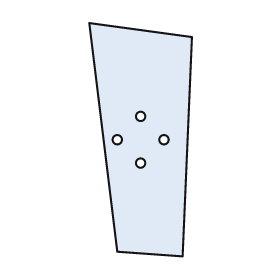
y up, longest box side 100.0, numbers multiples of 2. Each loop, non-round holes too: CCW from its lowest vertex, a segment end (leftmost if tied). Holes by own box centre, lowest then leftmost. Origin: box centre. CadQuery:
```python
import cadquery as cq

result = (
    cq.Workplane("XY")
    .moveTo(18.0, -50.0)
    .lineTo(22.0, 44.0)
    .lineTo(-22.0, 50.0)
    .lineTo(-10.0, -48.0)
    .close()
    .moveTo(0.0, -10.0)
    .circle(2.0)
    .moveTo(-10.0, 0.0)
    .circle(2.0)
    .moveTo(10.0, 0.0)
    .circle(2.0)
    .moveTo(0.0, 10.0)
    .circle(2.0)
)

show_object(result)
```